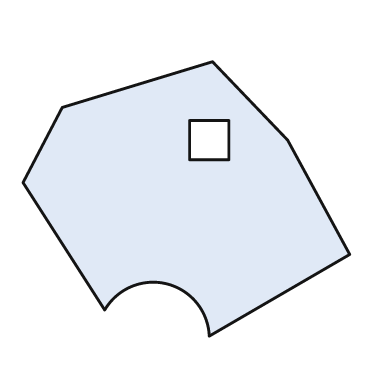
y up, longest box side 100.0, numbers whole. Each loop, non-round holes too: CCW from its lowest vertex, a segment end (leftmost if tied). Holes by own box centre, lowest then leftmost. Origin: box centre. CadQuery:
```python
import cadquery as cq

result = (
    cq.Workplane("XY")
    .moveTo(7.0, -42.0)
    .lineTo(50.0, -17.0)
    .lineTo(31.0, 18.0)
    .lineTo(8.0, 42.0)
    .lineTo(-38.0, 28.0)
    .lineTo(-50.0, 5.0)
    .lineTo(-25.0, -34.0)
    .threePointArc((-6.0, -26.0), (7.0, -42.0))
    .close()
    .moveTo(1.0, 12.0)
    .lineTo(13.0, 12.0)
    .lineTo(13.0, 24.0)
    .lineTo(1.0, 24.0)
    .close()
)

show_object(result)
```